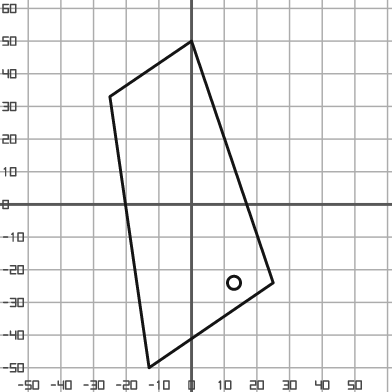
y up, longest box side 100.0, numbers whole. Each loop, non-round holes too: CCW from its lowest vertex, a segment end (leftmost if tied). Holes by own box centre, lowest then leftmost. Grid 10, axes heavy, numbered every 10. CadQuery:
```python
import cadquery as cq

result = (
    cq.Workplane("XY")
    .moveTo(-13.0, -50.0)
    .lineTo(25.0, -24.0)
    .lineTo(0.0, 50.0)
    .lineTo(-25.0, 33.0)
    .close()
    .moveTo(13.0, -24.0)
    .circle(2.0)
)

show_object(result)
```